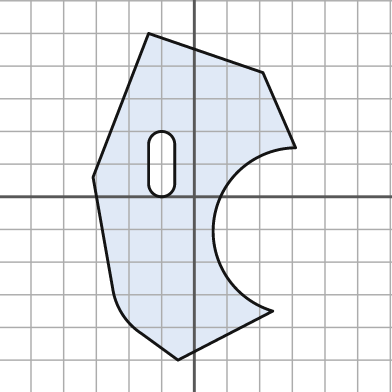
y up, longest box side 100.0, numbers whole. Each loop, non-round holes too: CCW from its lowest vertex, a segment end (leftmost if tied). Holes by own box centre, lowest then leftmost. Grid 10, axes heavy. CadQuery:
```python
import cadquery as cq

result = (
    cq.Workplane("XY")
    .moveTo(-5.0, -50.0)
    .lineTo(24.0, -35.0)
    .threePointArc((6.0, -7.0), (31.0, 15.0))
    .lineTo(21.0, 38.0)
    .lineTo(-14.0, 50.0)
    .lineTo(-31.0, 6.0)
    .lineTo(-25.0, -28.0)
    .threePointArc((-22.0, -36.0), (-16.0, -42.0))
    .close()
    .moveTo(-14.0, 4.0)
    .threePointArc((-10.0, 0.0), (-6.0, 4.0))
    .lineTo(-6.0, 16.0)
    .threePointArc((-10.0, 20.0), (-14.0, 16.0))
    .close()
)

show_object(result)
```